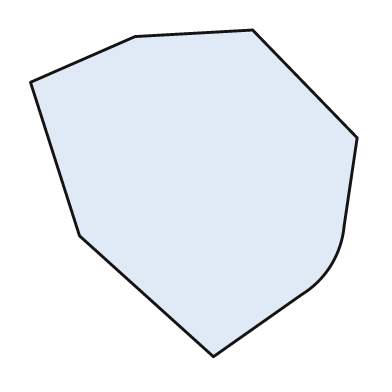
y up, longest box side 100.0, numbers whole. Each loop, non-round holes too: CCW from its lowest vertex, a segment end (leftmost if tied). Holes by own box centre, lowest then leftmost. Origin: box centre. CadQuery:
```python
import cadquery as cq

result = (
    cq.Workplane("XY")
    .moveTo(6.0, -50.0)
    .lineTo(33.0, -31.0)
    .threePointArc((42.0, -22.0), (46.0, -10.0))
    .lineTo(50.0, 17.0)
    .lineTo(18.0, 50.0)
    .lineTo(-18.0, 48.0)
    .lineTo(-50.0, 34.0)
    .lineTo(-35.0, -13.0)
    .close()
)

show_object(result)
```